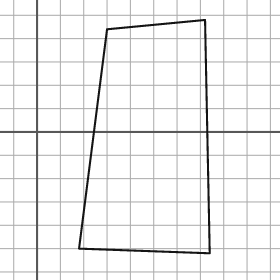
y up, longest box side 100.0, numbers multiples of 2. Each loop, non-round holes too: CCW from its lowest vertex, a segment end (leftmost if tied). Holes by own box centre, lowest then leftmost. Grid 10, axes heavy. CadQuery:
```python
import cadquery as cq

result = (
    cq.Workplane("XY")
    .moveTo(74.0, -52.0)
    .lineTo(72.0, 48.0)
    .lineTo(30.0, 44.0)
    .lineTo(18.0, -50.0)
    .close()
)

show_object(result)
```